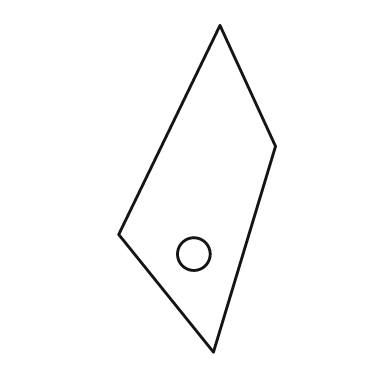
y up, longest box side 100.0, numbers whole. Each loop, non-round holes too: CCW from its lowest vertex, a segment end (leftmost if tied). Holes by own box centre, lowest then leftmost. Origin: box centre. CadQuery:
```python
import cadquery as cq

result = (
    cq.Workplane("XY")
    .moveTo(5.0, -50.0)
    .lineTo(24.0, 13.0)
    .lineTo(7.0, 50.0)
    .lineTo(-24.0, -14.0)
    .close()
    .moveTo(-1.0, -20.0)
    .circle(5.0)
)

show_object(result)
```